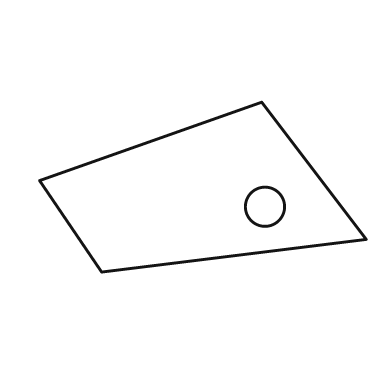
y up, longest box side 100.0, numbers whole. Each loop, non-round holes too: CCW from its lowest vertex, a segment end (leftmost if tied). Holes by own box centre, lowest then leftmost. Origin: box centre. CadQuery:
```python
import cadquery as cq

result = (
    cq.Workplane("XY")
    .moveTo(-31.0, -26.0)
    .lineTo(50.0, -16.0)
    .lineTo(18.0, 26.0)
    .lineTo(-50.0, 2.0)
    .close()
    .moveTo(19.0, -6.0)
    .circle(6.0)
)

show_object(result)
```